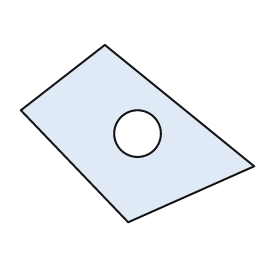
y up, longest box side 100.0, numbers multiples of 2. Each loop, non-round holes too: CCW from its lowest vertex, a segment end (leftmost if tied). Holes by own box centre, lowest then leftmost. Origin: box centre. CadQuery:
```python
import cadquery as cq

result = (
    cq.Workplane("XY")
    .moveTo(-4.0, -38.0)
    .lineTo(50.0, -14.0)
    .lineTo(-14.0, 38.0)
    .lineTo(-50.0, 10.0)
    .close()
    .moveTo(0.0, 0.0)
    .circle(10.0)
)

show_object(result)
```